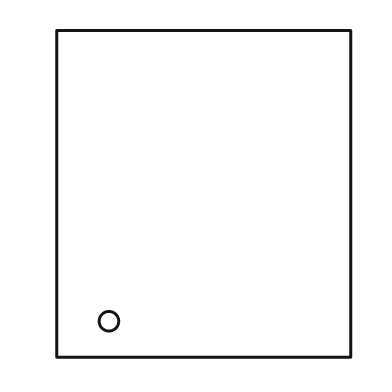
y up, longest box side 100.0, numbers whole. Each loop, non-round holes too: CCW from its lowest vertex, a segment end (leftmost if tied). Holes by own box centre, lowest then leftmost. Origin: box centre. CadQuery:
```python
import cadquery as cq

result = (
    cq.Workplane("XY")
    .moveTo(-45.0, -50.0)
    .lineTo(45.0, -50.0)
    .lineTo(45.0, 50.0)
    .lineTo(-45.0, 50.0)
    .close()
    .moveTo(-29.0, -39.0)
    .circle(3.0)
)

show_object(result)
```